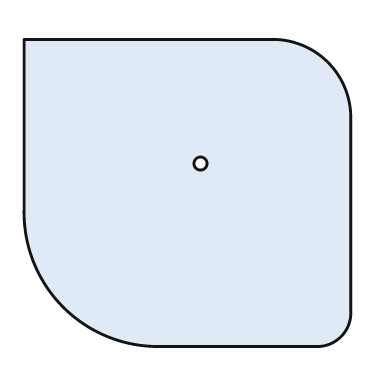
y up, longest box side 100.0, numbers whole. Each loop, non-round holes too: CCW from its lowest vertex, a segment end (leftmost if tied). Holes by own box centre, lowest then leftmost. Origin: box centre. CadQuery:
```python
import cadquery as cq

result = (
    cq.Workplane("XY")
    .moveTo(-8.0, -47.0)
    .lineTo(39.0, -47.0)
    .threePointArc((47.0, -44.0), (50.0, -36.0))
    .lineTo(50.0, 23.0)
    .threePointArc((43.0, 40.0), (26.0, 47.0))
    .lineTo(-50.0, 47.0)
    .lineTo(-50.0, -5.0)
    .threePointArc((-38.0, -35.0), (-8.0, -47.0))
    .close()
    .moveTo(4.0, 9.0)
    .circle(2.0)
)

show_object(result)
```